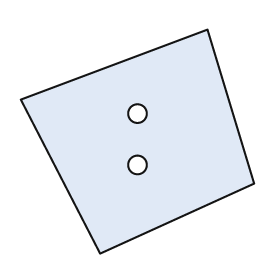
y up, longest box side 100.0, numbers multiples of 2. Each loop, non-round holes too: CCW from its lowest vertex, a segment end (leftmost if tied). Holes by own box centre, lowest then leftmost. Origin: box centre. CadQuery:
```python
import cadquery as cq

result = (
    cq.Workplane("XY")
    .moveTo(-16.0, -48.0)
    .lineTo(50.0, -18.0)
    .lineTo(30.0, 48.0)
    .lineTo(-50.0, 18.0)
    .close()
    .moveTo(0.0, -10.0)
    .circle(4.0)
    .moveTo(0.0, 12.0)
    .circle(4.0)
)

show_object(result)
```